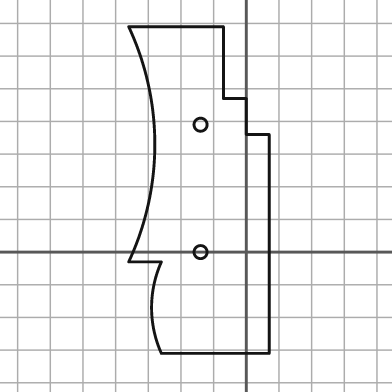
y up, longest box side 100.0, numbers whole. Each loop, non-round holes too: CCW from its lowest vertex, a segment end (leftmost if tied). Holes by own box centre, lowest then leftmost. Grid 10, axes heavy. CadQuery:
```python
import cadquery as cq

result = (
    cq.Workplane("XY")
    .moveTo(-26.0, -31.0)
    .lineTo(7.0, -31.0)
    .lineTo(7.0, 36.0)
    .lineTo(0.0, 36.0)
    .lineTo(0.0, 47.0)
    .lineTo(-7.0, 47.0)
    .lineTo(-7.0, 69.0)
    .lineTo(-36.0, 69.0)
    .threePointArc((-28.0, 33.0), (-36.0, -3.0))
    .lineTo(-26.0, -3.0)
    .threePointArc((-29.0, -17.0), (-26.0, -31.0))
    .close()
    .moveTo(-14.0, 0.0)
    .circle(2.0)
    .moveTo(-14.0, 39.0)
    .circle(2.0)
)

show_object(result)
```